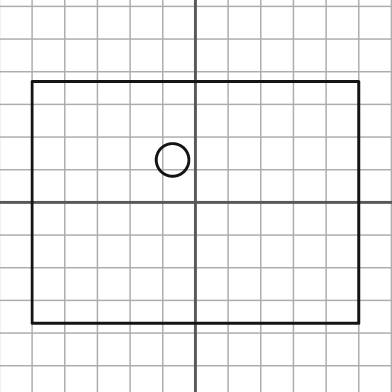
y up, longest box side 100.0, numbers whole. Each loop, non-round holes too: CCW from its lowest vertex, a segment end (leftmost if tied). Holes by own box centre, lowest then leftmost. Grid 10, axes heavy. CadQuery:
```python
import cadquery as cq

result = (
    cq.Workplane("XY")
    .moveTo(-50.0, -37.0)
    .lineTo(50.0, -37.0)
    .lineTo(50.0, 37.0)
    .lineTo(-50.0, 37.0)
    .close()
    .moveTo(-7.0, 13.0)
    .circle(5.0)
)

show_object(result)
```